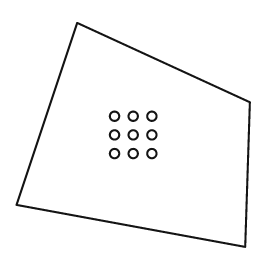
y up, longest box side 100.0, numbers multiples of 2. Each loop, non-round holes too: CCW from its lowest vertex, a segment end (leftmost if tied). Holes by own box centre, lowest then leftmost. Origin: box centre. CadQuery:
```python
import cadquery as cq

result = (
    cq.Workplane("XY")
    .moveTo(48.0, -48.0)
    .lineTo(50.0, 14.0)
    .lineTo(-24.0, 48.0)
    .lineTo(-50.0, -30.0)
    .close()
    .moveTo(-8.0, -8.0)
    .circle(2.0)
    .moveTo(0.0, -8.0)
    .circle(2.0)
    .moveTo(8.0, -8.0)
    .circle(2.0)
    .moveTo(-8.0, 0.0)
    .circle(2.0)
    .moveTo(0.0, 0.0)
    .circle(2.0)
    .moveTo(8.0, 0.0)
    .circle(2.0)
    .moveTo(-8.0, 8.0)
    .circle(2.0)
    .moveTo(0.0, 8.0)
    .circle(2.0)
    .moveTo(8.0, 8.0)
    .circle(2.0)
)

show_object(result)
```